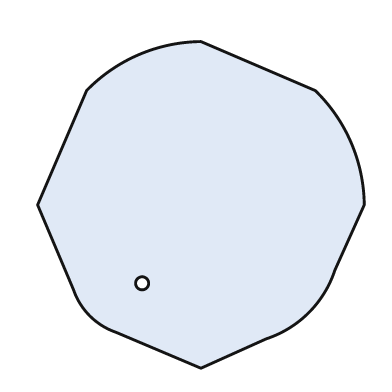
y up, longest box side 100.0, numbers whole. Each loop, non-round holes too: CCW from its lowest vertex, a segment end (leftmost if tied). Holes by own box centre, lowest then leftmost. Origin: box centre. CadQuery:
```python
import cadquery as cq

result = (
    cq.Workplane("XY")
    .moveTo(0.0, -50.0)
    .lineTo(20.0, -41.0)
    .threePointArc((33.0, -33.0), (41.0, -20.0))
    .lineTo(50.0, 0.0)
    .threePointArc((46.0, 19.0), (35.0, 35.0))
    .lineTo(0.0, 50.0)
    .threePointArc((-19.0, 46.0), (-35.0, 35.0))
    .lineTo(-50.0, 0.0)
    .lineTo(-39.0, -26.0)
    .threePointArc((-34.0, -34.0), (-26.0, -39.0))
    .close()
    .moveTo(-18.0, -24.0)
    .circle(2.0)
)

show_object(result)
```